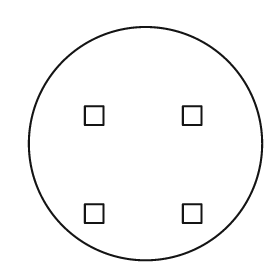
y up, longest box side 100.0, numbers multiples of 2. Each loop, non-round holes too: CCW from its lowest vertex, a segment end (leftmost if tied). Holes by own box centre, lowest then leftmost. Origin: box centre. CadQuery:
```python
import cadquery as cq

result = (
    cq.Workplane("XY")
    .moveTo(0.0, 0.0)
    .circle(50.0)
    .moveTo(-26.0, -34.0)
    .lineTo(-18.0, -34.0)
    .lineTo(-18.0, -26.0)
    .lineTo(-26.0, -26.0)
    .close()
    .moveTo(16.0, -34.0)
    .lineTo(24.0, -34.0)
    .lineTo(24.0, -26.0)
    .lineTo(16.0, -26.0)
    .close()
    .moveTo(-26.0, 8.0)
    .lineTo(-18.0, 8.0)
    .lineTo(-18.0, 16.0)
    .lineTo(-26.0, 16.0)
    .close()
    .moveTo(16.0, 8.0)
    .lineTo(24.0, 8.0)
    .lineTo(24.0, 16.0)
    .lineTo(16.0, 16.0)
    .close()
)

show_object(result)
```